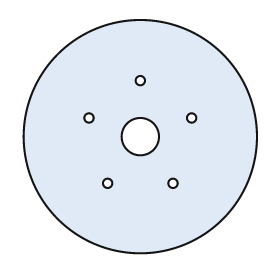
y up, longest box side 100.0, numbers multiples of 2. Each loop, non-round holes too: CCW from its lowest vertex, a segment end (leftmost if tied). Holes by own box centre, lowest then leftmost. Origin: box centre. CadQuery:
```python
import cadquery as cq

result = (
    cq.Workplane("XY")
    .moveTo(0.0, 0.0)
    .circle(50.0)
    .moveTo(-14.0, -20.0)
    .circle(2.0)
    .moveTo(14.0, -20.0)
    .circle(2.0)
    .moveTo(0.0, 0.0)
    .circle(8.0)
    .moveTo(-22.0, 8.0)
    .circle(2.0)
    .moveTo(22.0, 8.0)
    .circle(2.0)
    .moveTo(0.0, 24.0)
    .circle(2.0)
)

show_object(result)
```